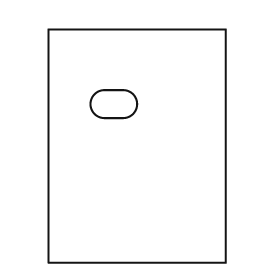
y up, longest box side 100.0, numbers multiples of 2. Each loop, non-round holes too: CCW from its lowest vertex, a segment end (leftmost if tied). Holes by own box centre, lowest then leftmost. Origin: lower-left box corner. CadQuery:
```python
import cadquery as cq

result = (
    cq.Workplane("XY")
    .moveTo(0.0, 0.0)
    .lineTo(76.0, 0.0)
    .lineTo(76.0, 100.0)
    .lineTo(0.0, 100.0)
    .close()
    .moveTo(24.0, 62.0)
    .lineTo(32.0, 62.0)
    .threePointArc((38.0, 68.0), (32.0, 74.0))
    .lineTo(24.0, 74.0)
    .threePointArc((18.0, 68.0), (24.0, 62.0))
    .close()
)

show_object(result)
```